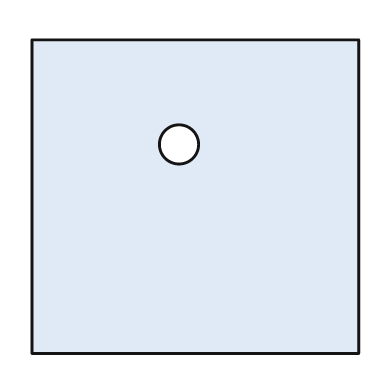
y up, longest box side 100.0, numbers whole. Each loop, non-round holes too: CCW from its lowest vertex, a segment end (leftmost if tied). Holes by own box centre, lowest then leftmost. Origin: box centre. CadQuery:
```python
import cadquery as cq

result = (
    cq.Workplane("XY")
    .moveTo(-50.0, -48.0)
    .lineTo(50.0, -48.0)
    .lineTo(50.0, 48.0)
    .lineTo(-50.0, 48.0)
    .close()
    .moveTo(-5.0, 16.0)
    .circle(6.0)
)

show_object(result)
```